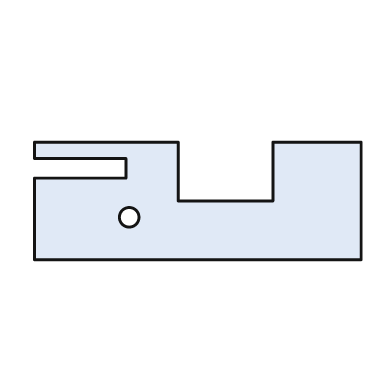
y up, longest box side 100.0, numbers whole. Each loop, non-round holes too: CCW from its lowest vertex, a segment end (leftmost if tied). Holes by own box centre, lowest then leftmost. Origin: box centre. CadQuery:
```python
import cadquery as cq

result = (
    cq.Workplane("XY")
    .moveTo(-50.0, -18.0)
    .lineTo(50.0, -18.0)
    .lineTo(50.0, 18.0)
    .lineTo(23.0, 18.0)
    .lineTo(23.0, 0.0)
    .lineTo(-6.0, 0.0)
    .lineTo(-6.0, 18.0)
    .lineTo(-50.0, 18.0)
    .lineTo(-50.0, 13.0)
    .lineTo(-22.0, 13.0)
    .lineTo(-22.0, 7.0)
    .lineTo(-50.0, 7.0)
    .close()
    .moveTo(-21.0, -5.0)
    .circle(3.0)
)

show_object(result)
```